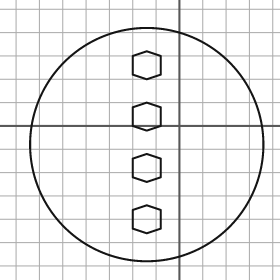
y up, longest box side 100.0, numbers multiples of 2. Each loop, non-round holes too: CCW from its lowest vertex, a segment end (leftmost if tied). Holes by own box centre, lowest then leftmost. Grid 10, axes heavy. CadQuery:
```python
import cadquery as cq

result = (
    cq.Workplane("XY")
    .moveTo(-14.0, -8.0)
    .circle(50.0)
    .moveTo(-14.0, -46.0)
    .lineTo(-8.0, -44.0)
    .lineTo(-8.0, -36.0)
    .lineTo(-14.0, -34.0)
    .lineTo(-20.0, -36.0)
    .lineTo(-20.0, -44.0)
    .close()
    .moveTo(-14.0, -24.0)
    .lineTo(-8.0, -22.0)
    .lineTo(-8.0, -14.0)
    .lineTo(-14.0, -12.0)
    .lineTo(-20.0, -14.0)
    .lineTo(-20.0, -22.0)
    .close()
    .moveTo(-14.0, -2.0)
    .lineTo(-8.0, 0.0)
    .lineTo(-8.0, 8.0)
    .lineTo(-14.0, 10.0)
    .lineTo(-20.0, 8.0)
    .lineTo(-20.0, 0.0)
    .close()
    .moveTo(-14.0, 20.0)
    .lineTo(-8.0, 22.0)
    .lineTo(-8.0, 30.0)
    .lineTo(-14.0, 32.0)
    .lineTo(-20.0, 30.0)
    .lineTo(-20.0, 22.0)
    .close()
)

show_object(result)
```